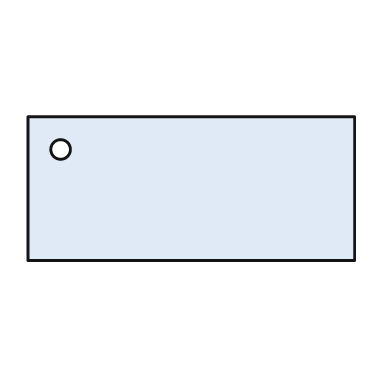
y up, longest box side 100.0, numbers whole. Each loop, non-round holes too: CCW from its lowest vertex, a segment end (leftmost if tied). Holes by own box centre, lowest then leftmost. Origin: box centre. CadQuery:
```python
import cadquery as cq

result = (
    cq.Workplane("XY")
    .moveTo(-50.0, -22.0)
    .lineTo(50.0, -22.0)
    .lineTo(50.0, 22.0)
    .lineTo(-50.0, 22.0)
    .close()
    .moveTo(-40.0, 12.0)
    .circle(3.0)
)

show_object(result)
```